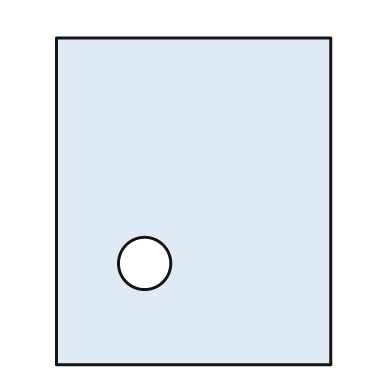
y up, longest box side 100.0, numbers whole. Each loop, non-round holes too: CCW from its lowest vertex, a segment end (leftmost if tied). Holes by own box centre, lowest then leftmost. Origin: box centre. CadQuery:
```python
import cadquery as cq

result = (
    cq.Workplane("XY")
    .moveTo(-42.0, -50.0)
    .lineTo(42.0, -50.0)
    .lineTo(42.0, 50.0)
    .lineTo(-42.0, 50.0)
    .close()
    .moveTo(-15.0, -19.0)
    .circle(8.0)
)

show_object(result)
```